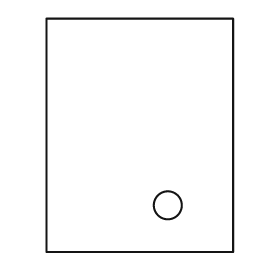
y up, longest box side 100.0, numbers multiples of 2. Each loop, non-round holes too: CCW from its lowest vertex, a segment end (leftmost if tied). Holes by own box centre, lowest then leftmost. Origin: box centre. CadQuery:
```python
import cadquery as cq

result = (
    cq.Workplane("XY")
    .moveTo(-40.0, -50.0)
    .lineTo(40.0, -50.0)
    .lineTo(40.0, 50.0)
    .lineTo(-40.0, 50.0)
    .close()
    .moveTo(12.0, -30.0)
    .circle(6.0)
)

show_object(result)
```